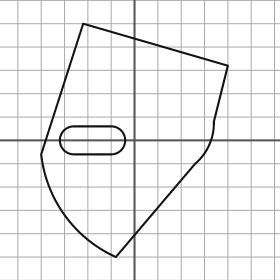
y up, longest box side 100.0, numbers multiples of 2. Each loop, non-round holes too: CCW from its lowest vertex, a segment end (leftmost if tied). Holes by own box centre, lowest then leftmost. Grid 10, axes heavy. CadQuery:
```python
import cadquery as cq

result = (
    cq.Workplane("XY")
    .moveTo(-8.0, -50.0)
    .lineTo(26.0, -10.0)
    .threePointArc((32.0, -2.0), (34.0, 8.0))
    .lineTo(40.0, 32.0)
    .lineTo(-22.0, 50.0)
    .lineTo(-40.0, -6.0)
    .threePointArc((-30.0, -32.0), (-8.0, -50.0))
    .close()
    .moveTo(-26.0, -6.0)
    .lineTo(-10.0, -6.0)
    .threePointArc((-4.0, 0.0), (-10.0, 6.0))
    .lineTo(-26.0, 6.0)
    .threePointArc((-32.0, 0.0), (-26.0, -6.0))
    .close()
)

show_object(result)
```